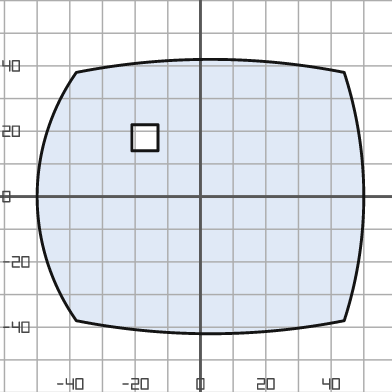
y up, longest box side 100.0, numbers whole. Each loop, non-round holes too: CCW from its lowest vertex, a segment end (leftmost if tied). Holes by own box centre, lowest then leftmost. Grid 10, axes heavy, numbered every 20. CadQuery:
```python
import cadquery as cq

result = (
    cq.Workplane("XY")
    .moveTo(-38.0, -38.0)
    .threePointArc((3.0, -42.0), (44.0, -38.0))
    .threePointArc((50.0, 0.0), (44.0, 38.0))
    .threePointArc((3.0, 42.0), (-38.0, 38.0))
    .threePointArc((-50.0, 0.0), (-38.0, -38.0))
    .close()
    .moveTo(-21.0, 14.0)
    .lineTo(-13.0, 14.0)
    .lineTo(-13.0, 22.0)
    .lineTo(-21.0, 22.0)
    .close()
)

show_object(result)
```